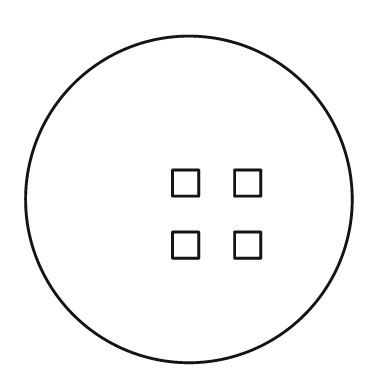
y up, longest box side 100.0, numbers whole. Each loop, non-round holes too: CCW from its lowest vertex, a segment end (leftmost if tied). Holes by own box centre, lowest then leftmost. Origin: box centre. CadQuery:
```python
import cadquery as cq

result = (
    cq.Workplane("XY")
    .moveTo(0.0, 0.0)
    .circle(50.0)
    .moveTo(-5.0, -18.0)
    .lineTo(3.0, -18.0)
    .lineTo(3.0, -10.0)
    .lineTo(-5.0, -10.0)
    .close()
    .moveTo(14.0, -18.0)
    .lineTo(22.0, -18.0)
    .lineTo(22.0, -10.0)
    .lineTo(14.0, -10.0)
    .close()
    .moveTo(-5.0, 1.0)
    .lineTo(3.0, 1.0)
    .lineTo(3.0, 9.0)
    .lineTo(-5.0, 9.0)
    .close()
    .moveTo(14.0, 1.0)
    .lineTo(22.0, 1.0)
    .lineTo(22.0, 9.0)
    .lineTo(14.0, 9.0)
    .close()
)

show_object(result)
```